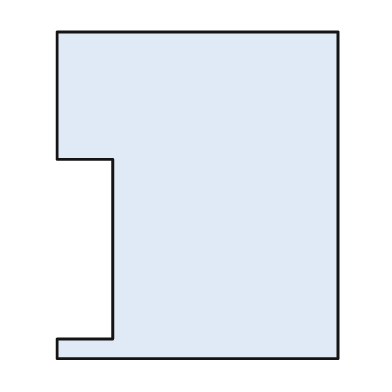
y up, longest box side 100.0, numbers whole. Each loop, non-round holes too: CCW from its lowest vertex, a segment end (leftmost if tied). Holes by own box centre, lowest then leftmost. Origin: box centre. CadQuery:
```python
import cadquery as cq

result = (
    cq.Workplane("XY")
    .moveTo(-43.0, -50.0)
    .lineTo(43.0, -50.0)
    .lineTo(43.0, 50.0)
    .lineTo(-43.0, 50.0)
    .lineTo(-43.0, 11.0)
    .lineTo(-26.0, 11.0)
    .lineTo(-26.0, -44.0)
    .lineTo(-43.0, -44.0)
    .close()
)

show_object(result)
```